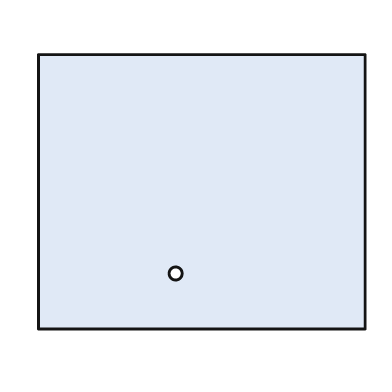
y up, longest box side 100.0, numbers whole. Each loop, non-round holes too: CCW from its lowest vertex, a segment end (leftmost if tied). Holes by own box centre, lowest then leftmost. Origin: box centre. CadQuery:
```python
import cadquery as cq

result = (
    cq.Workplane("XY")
    .moveTo(-50.0, -42.0)
    .lineTo(50.0, -42.0)
    .lineTo(50.0, 42.0)
    .lineTo(-50.0, 42.0)
    .close()
    .moveTo(-8.0, -25.0)
    .circle(2.0)
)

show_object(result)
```